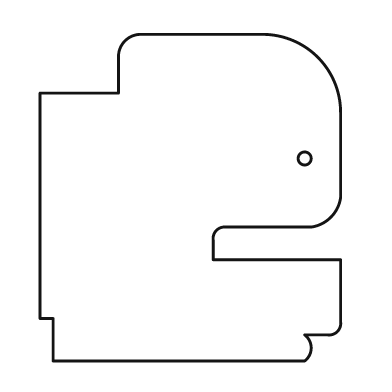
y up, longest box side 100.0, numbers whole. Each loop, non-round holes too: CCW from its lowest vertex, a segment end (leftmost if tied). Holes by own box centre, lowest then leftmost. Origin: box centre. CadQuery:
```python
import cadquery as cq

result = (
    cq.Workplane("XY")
    .moveTo(-42.0, -50.0)
    .lineTo(35.0, -50.0)
    .threePointArc((37.0, -46.0), (35.0, -42.0))
    .lineTo(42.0, -42.0)
    .threePointArc((45.0, -41.0), (46.0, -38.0))
    .lineTo(46.0, -19.0)
    .lineTo(7.0, -19.0)
    .lineTo(7.0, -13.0)
    .threePointArc((8.0, -10.0), (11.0, -9.0))
    .lineTo(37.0, -9.0)
    .threePointArc((43.0, -6.0), (46.0, 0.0))
    .lineTo(46.0, 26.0)
    .threePointArc((39.0, 43.0), (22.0, 50.0))
    .lineTo(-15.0, 50.0)
    .threePointArc((-20.0, 48.0), (-22.0, 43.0))
    .lineTo(-22.0, 32.0)
    .lineTo(-46.0, 32.0)
    .lineTo(-46.0, -37.0)
    .lineTo(-42.0, -37.0)
    .close()
    .moveTo(35.0, 12.0)
    .circle(2.0)
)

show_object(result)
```